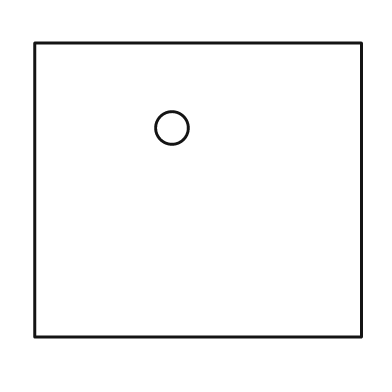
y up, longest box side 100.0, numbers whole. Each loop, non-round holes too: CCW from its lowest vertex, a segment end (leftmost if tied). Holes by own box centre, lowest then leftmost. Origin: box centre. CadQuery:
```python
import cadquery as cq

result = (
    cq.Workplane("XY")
    .moveTo(-50.0, -45.0)
    .lineTo(50.0, -45.0)
    .lineTo(50.0, 45.0)
    .lineTo(-50.0, 45.0)
    .close()
    .moveTo(-8.0, 19.0)
    .circle(5.0)
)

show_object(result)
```